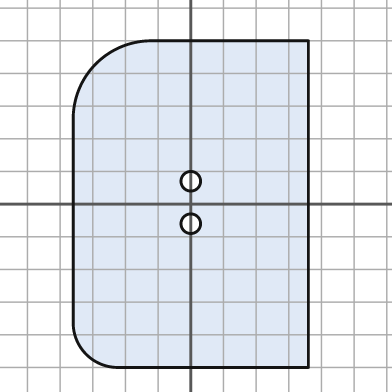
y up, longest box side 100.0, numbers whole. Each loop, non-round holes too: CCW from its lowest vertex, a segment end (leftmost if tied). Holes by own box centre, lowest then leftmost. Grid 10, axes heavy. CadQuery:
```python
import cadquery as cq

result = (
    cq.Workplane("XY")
    .moveTo(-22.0, -50.0)
    .lineTo(36.0, -50.0)
    .lineTo(36.0, 50.0)
    .lineTo(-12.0, 50.0)
    .threePointArc((-29.0, 43.0), (-36.0, 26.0))
    .lineTo(-36.0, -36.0)
    .threePointArc((-32.0, -46.0), (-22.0, -50.0))
    .close()
    .moveTo(0.0, -6.0)
    .circle(3.0)
    .moveTo(0.0, 7.0)
    .circle(3.0)
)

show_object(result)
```